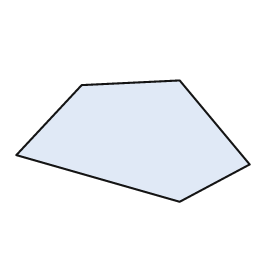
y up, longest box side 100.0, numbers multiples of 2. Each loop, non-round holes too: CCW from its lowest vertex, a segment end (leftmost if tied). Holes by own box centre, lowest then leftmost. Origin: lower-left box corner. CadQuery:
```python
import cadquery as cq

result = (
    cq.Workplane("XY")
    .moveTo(70.0, 0.0)
    .lineTo(100.0, 16.0)
    .lineTo(70.0, 52.0)
    .lineTo(28.0, 50.0)
    .lineTo(0.0, 20.0)
    .close()
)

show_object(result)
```